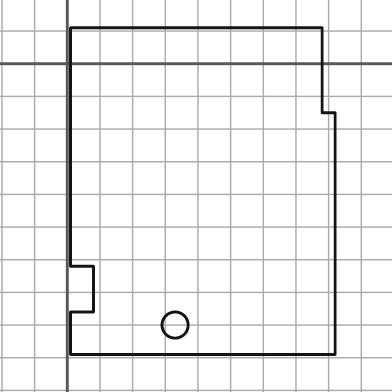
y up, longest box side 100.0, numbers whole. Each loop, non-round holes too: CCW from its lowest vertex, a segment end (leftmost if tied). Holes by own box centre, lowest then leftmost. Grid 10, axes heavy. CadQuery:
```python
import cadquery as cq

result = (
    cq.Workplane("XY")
    .moveTo(1.0, -89.0)
    .lineTo(82.0, -89.0)
    .lineTo(82.0, -15.0)
    .lineTo(78.0, -15.0)
    .lineTo(78.0, 11.0)
    .lineTo(1.0, 11.0)
    .lineTo(1.0, -62.0)
    .lineTo(8.0, -62.0)
    .lineTo(8.0, -76.0)
    .lineTo(1.0, -76.0)
    .close()
    .moveTo(33.0, -80.0)
    .circle(4.0)
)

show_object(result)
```